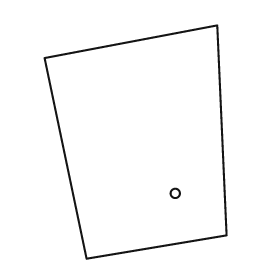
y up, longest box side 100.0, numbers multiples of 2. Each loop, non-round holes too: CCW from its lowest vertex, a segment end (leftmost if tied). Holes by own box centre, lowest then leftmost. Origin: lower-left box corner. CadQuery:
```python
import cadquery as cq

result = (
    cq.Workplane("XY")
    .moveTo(18.0, 0.0)
    .lineTo(78.0, 10.0)
    .lineTo(74.0, 100.0)
    .lineTo(0.0, 86.0)
    .close()
    .moveTo(56.0, 28.0)
    .circle(2.0)
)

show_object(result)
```